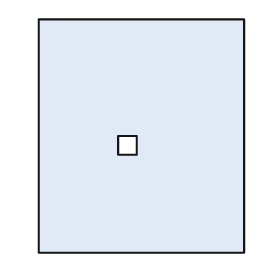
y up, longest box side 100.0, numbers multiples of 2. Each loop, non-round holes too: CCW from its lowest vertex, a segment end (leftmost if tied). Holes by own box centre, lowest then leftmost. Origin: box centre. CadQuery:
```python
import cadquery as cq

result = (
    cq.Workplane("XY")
    .moveTo(-44.0, -50.0)
    .lineTo(44.0, -50.0)
    .lineTo(44.0, 50.0)
    .lineTo(-44.0, 50.0)
    .close()
    .moveTo(-10.0, -8.0)
    .lineTo(-2.0, -8.0)
    .lineTo(-2.0, 0.0)
    .lineTo(-10.0, 0.0)
    .close()
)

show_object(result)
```